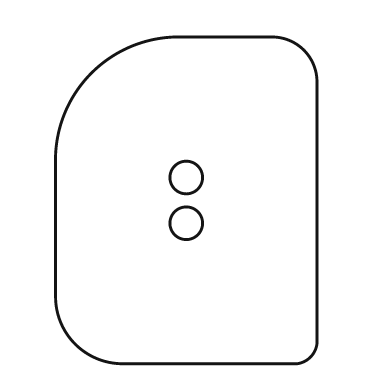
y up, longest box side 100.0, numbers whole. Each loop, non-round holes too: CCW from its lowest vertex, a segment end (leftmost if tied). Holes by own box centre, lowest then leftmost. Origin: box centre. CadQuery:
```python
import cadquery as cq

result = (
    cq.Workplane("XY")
    .moveTo(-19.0, -50.0)
    .lineTo(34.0, -50.0)
    .threePointArc((38.0, -48.0), (40.0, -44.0))
    .lineTo(40.0, 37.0)
    .threePointArc((36.0, 46.0), (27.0, 50.0))
    .lineTo(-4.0, 50.0)
    .threePointArc((-29.0, 39.0), (-40.0, 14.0))
    .lineTo(-40.0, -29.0)
    .threePointArc((-34.0, -44.0), (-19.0, -50.0))
    .close()
    .moveTo(0.0, -7.0)
    .circle(5.0)
    .moveTo(0.0, 7.0)
    .circle(5.0)
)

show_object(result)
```